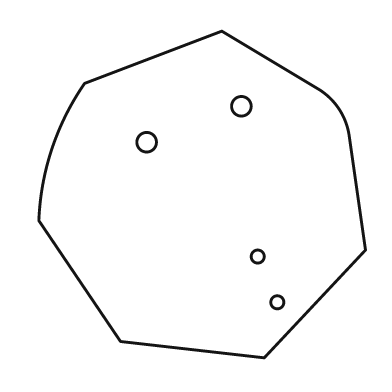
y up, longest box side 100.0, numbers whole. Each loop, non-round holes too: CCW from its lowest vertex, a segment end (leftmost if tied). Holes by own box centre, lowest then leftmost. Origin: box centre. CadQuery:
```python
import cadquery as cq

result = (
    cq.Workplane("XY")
    .moveTo(19.0, -50.0)
    .lineTo(50.0, -17.0)
    .lineTo(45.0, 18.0)
    .threePointArc((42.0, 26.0), (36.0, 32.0))
    .lineTo(6.0, 50.0)
    .lineTo(-36.0, 34.0)
    .threePointArc((-46.0, 14.0), (-50.0, -8.0))
    .lineTo(-25.0, -45.0)
    .close()
    .moveTo(23.0, -33.0)
    .circle(2.0)
    .moveTo(17.0, -19.0)
    .circle(2.0)
    .moveTo(-17.0, 16.0)
    .circle(3.0)
    .moveTo(12.0, 27.0)
    .circle(3.0)
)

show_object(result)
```